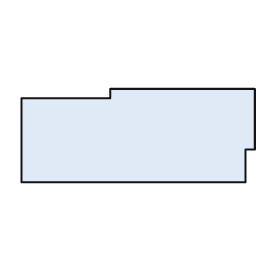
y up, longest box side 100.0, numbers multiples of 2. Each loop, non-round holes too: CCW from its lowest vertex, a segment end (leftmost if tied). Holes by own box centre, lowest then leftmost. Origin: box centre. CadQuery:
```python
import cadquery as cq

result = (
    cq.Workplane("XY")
    .moveTo(-50.0, -20.0)
    .lineTo(46.0, -20.0)
    .lineTo(46.0, -6.0)
    .lineTo(50.0, -6.0)
    .lineTo(50.0, 20.0)
    .lineTo(-12.0, 20.0)
    .lineTo(-12.0, 16.0)
    .lineTo(-50.0, 16.0)
    .close()
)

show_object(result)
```